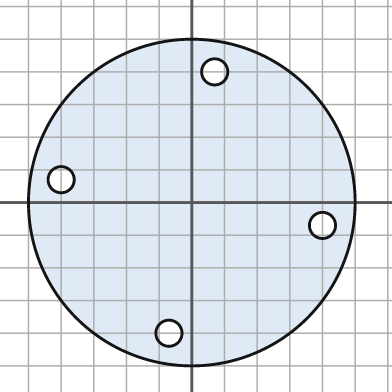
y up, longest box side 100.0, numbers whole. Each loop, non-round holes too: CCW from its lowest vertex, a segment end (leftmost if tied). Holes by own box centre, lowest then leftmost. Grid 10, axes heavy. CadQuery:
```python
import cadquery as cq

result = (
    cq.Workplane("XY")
    .moveTo(0.0, 0.0)
    .circle(50.0)
    .moveTo(-7.0, -40.0)
    .circle(4.0)
    .moveTo(40.0, -7.0)
    .circle(4.0)
    .moveTo(-40.0, 7.0)
    .circle(4.0)
    .moveTo(7.0, 40.0)
    .circle(4.0)
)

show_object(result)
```